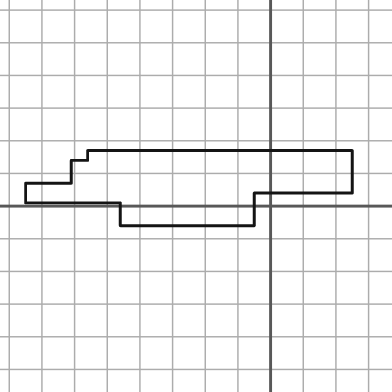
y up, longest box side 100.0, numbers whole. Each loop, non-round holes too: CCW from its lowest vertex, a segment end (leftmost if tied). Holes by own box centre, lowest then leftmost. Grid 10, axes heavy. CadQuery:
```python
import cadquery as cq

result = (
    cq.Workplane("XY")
    .moveTo(-46.0, -6.0)
    .lineTo(-5.0, -6.0)
    .lineTo(-5.0, 4.0)
    .lineTo(25.0, 4.0)
    .lineTo(25.0, 17.0)
    .lineTo(-56.0, 17.0)
    .lineTo(-56.0, 14.0)
    .lineTo(-61.0, 14.0)
    .lineTo(-61.0, 7.0)
    .lineTo(-75.0, 7.0)
    .lineTo(-75.0, 1.0)
    .lineTo(-46.0, 1.0)
    .close()
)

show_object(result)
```